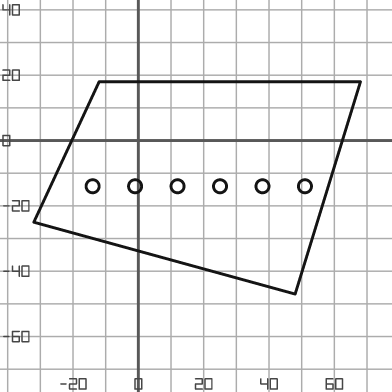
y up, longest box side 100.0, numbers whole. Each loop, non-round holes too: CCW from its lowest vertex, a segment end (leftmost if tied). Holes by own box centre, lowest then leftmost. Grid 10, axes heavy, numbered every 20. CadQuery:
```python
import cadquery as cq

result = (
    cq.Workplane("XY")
    .moveTo(48.0, -47.0)
    .lineTo(68.0, 18.0)
    .lineTo(-12.0, 18.0)
    .lineTo(-32.0, -25.0)
    .close()
    .moveTo(-14.0, -14.0)
    .circle(2.0)
    .moveTo(-1.0, -14.0)
    .circle(2.0)
    .moveTo(12.0, -14.0)
    .circle(2.0)
    .moveTo(25.0, -14.0)
    .circle(2.0)
    .moveTo(38.0, -14.0)
    .circle(2.0)
    .moveTo(51.0, -14.0)
    .circle(2.0)
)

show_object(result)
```